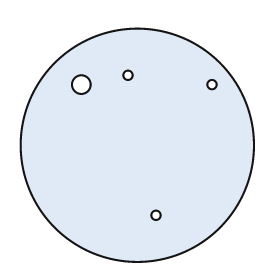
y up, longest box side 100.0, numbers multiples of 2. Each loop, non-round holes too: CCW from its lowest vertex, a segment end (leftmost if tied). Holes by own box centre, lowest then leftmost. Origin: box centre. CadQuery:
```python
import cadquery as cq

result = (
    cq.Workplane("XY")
    .moveTo(0.0, 0.0)
    .circle(50.0)
    .moveTo(8.0, -30.0)
    .circle(2.0)
    .moveTo(-24.0, 26.0)
    .circle(4.0)
    .moveTo(32.0, 26.0)
    .circle(2.0)
    .moveTo(-4.0, 30.0)
    .circle(2.0)
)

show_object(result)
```